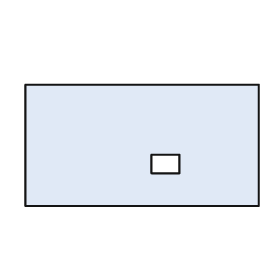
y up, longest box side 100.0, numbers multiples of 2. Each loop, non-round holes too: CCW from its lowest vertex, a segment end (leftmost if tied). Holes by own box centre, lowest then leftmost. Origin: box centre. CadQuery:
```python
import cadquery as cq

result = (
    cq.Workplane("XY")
    .moveTo(-50.0, -26.0)
    .lineTo(50.0, -26.0)
    .lineTo(50.0, 26.0)
    .lineTo(-50.0, 26.0)
    .close()
    .moveTo(4.0, -12.0)
    .lineTo(16.0, -12.0)
    .lineTo(16.0, -4.0)
    .lineTo(4.0, -4.0)
    .close()
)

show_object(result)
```